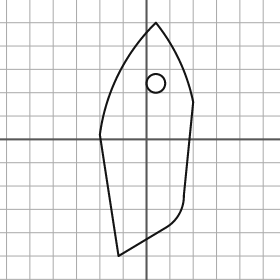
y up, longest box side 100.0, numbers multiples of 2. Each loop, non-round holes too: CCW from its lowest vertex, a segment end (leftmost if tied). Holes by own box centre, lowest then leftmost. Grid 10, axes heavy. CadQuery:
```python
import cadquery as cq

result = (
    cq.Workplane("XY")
    .moveTo(-12.0, -50.0)
    .lineTo(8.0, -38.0)
    .threePointArc((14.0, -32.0), (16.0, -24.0))
    .lineTo(20.0, 16.0)
    .threePointArc((14.0, 34.0), (4.0, 50.0))
    .threePointArc((-12.0, 28.0), (-20.0, 2.0))
    .close()
    .moveTo(4.0, 24.0)
    .circle(4.0)
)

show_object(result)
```